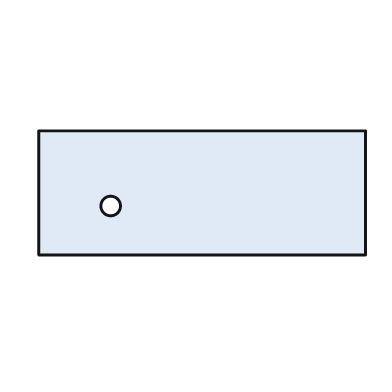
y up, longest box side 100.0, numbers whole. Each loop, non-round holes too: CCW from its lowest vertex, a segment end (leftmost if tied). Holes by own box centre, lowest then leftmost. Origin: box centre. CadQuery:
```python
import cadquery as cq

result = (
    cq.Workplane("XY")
    .moveTo(-50.0, -19.0)
    .lineTo(50.0, -19.0)
    .lineTo(50.0, 19.0)
    .lineTo(-50.0, 19.0)
    .close()
    .moveTo(-28.0, -4.0)
    .circle(3.0)
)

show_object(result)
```